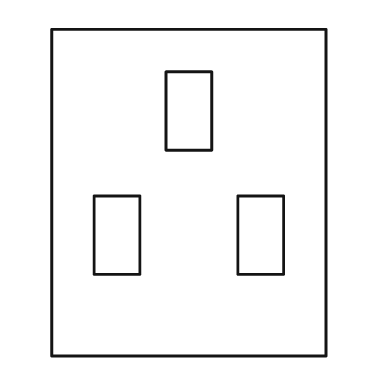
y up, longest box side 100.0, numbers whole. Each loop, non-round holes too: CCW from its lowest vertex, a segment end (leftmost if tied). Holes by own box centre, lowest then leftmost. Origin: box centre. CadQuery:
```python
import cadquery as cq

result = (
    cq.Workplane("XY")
    .moveTo(-42.0, -50.0)
    .lineTo(42.0, -50.0)
    .lineTo(42.0, 50.0)
    .lineTo(-42.0, 50.0)
    .close()
    .moveTo(-29.0, -25.0)
    .lineTo(-15.0, -25.0)
    .lineTo(-15.0, -1.0)
    .lineTo(-29.0, -1.0)
    .close()
    .moveTo(15.0, -25.0)
    .lineTo(29.0, -25.0)
    .lineTo(29.0, -1.0)
    .lineTo(15.0, -1.0)
    .close()
    .moveTo(-7.0, 13.0)
    .lineTo(7.0, 13.0)
    .lineTo(7.0, 37.0)
    .lineTo(-7.0, 37.0)
    .close()
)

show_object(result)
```